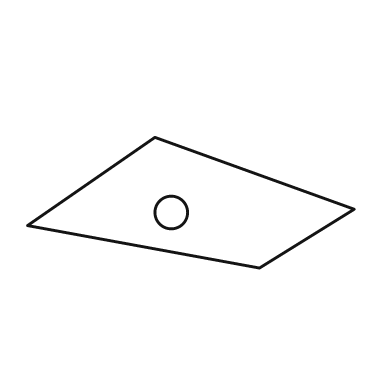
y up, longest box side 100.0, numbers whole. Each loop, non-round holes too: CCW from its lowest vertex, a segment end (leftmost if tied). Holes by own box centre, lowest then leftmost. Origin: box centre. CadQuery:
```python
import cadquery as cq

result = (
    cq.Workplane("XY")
    .moveTo(21.0, -20.0)
    .lineTo(50.0, -2.0)
    .lineTo(-11.0, 20.0)
    .lineTo(-50.0, -7.0)
    .close()
    .moveTo(-6.0, -3.0)
    .circle(5.0)
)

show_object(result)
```